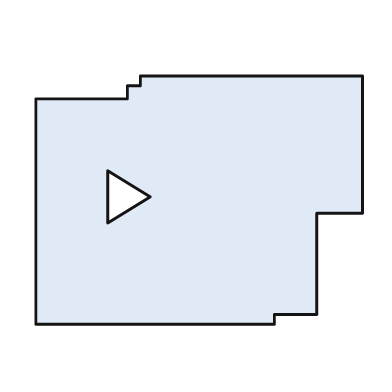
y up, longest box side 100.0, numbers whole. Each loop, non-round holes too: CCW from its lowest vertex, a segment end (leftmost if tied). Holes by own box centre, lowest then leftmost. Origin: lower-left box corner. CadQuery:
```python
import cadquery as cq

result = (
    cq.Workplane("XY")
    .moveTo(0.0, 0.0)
    .lineTo(73.0, 0.0)
    .lineTo(73.0, 3.0)
    .lineTo(86.0, 3.0)
    .lineTo(86.0, 34.0)
    .lineTo(100.0, 34.0)
    .lineTo(100.0, 76.0)
    .lineTo(32.0, 76.0)
    .lineTo(32.0, 73.0)
    .lineTo(28.0, 73.0)
    .lineTo(28.0, 69.0)
    .lineTo(0.0, 69.0)
    .close()
    .moveTo(22.0, 31.0)
    .lineTo(35.0, 39.0)
    .lineTo(22.0, 47.0)
    .close()
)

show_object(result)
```